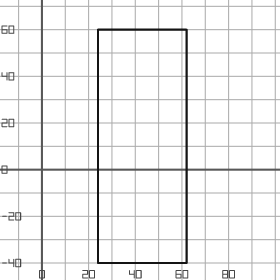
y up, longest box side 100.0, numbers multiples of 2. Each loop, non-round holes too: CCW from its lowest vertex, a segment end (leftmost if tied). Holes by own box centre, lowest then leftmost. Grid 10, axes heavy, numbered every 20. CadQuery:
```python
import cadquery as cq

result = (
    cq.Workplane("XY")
    .moveTo(24.0, -40.0)
    .lineTo(62.0, -40.0)
    .lineTo(62.0, 60.0)
    .lineTo(24.0, 60.0)
    .close()
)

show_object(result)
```